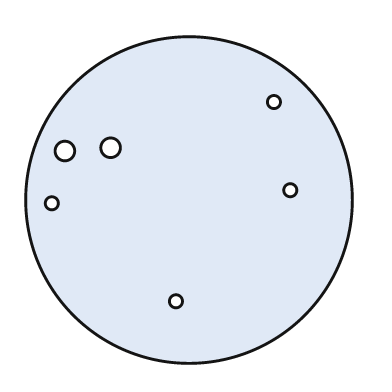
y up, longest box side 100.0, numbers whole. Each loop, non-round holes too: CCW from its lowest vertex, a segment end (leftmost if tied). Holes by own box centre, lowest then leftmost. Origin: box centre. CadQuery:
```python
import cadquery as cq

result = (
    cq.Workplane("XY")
    .moveTo(0.0, 0.0)
    .circle(50.0)
    .moveTo(-4.0, -31.0)
    .circle(2.0)
    .moveTo(-42.0, -1.0)
    .circle(2.0)
    .moveTo(31.0, 3.0)
    .circle(2.0)
    .moveTo(-38.0, 15.0)
    .circle(3.0)
    .moveTo(-24.0, 16.0)
    .circle(3.0)
    .moveTo(26.0, 30.0)
    .circle(2.0)
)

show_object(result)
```